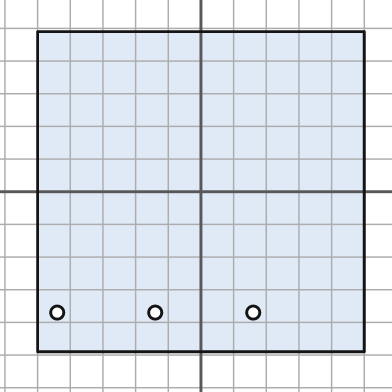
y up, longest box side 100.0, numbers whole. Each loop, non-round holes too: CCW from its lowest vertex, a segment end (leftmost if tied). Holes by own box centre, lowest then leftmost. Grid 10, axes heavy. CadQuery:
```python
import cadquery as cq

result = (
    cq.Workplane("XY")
    .moveTo(-50.0, -49.0)
    .lineTo(50.0, -49.0)
    .lineTo(50.0, 49.0)
    .lineTo(-50.0, 49.0)
    .close()
    .moveTo(-44.0, -37.0)
    .circle(2.0)
    .moveTo(-14.0, -37.0)
    .circle(2.0)
    .moveTo(16.0, -37.0)
    .circle(2.0)
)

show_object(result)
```